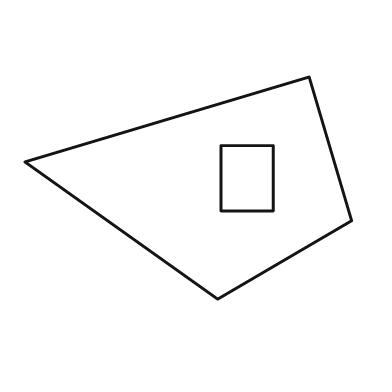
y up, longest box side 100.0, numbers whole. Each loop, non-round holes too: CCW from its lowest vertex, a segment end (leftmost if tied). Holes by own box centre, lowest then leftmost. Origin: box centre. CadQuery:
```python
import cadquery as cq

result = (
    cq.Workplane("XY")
    .moveTo(9.0, -34.0)
    .lineTo(50.0, -10.0)
    .lineTo(37.0, 34.0)
    .lineTo(-50.0, 8.0)
    .close()
    .moveTo(10.0, -7.0)
    .lineTo(26.0, -7.0)
    .lineTo(26.0, 13.0)
    .lineTo(10.0, 13.0)
    .close()
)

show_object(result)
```